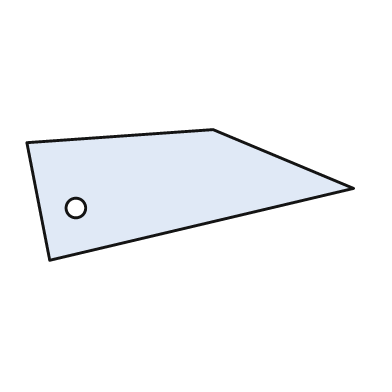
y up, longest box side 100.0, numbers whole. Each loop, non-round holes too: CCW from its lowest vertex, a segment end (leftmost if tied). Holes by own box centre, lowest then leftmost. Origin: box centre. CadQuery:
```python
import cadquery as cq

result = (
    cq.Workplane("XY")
    .moveTo(-43.0, -20.0)
    .lineTo(50.0, 2.0)
    .lineTo(7.0, 20.0)
    .lineTo(-50.0, 16.0)
    .close()
    .moveTo(-35.0, -4.0)
    .circle(3.0)
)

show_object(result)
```